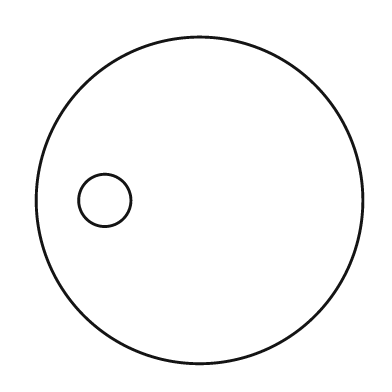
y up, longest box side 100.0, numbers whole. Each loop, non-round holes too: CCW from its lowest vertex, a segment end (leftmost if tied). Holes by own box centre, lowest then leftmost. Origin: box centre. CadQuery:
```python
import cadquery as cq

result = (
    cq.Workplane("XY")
    .moveTo(0.0, 0.0)
    .circle(50.0)
    .moveTo(-29.0, 0.0)
    .circle(8.0)
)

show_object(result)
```